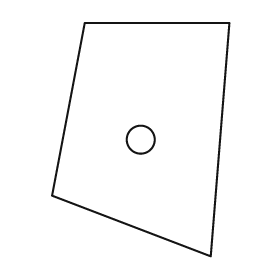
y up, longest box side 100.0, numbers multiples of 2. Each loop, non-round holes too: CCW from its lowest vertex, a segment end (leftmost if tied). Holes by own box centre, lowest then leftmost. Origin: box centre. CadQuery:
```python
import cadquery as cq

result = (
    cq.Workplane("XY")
    .moveTo(30.0, -50.0)
    .lineTo(38.0, 50.0)
    .lineTo(-24.0, 50.0)
    .lineTo(-38.0, -24.0)
    .close()
    .moveTo(0.0, 0.0)
    .circle(6.0)
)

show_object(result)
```